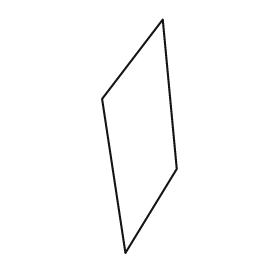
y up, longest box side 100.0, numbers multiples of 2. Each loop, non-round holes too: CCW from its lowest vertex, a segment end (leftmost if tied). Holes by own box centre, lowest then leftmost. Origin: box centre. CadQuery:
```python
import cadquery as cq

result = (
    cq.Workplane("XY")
    .moveTo(-6.0, -50.0)
    .lineTo(16.0, -14.0)
    .lineTo(10.0, 50.0)
    .lineTo(-16.0, 16.0)
    .close()
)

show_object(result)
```